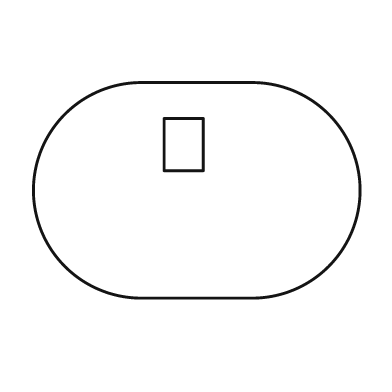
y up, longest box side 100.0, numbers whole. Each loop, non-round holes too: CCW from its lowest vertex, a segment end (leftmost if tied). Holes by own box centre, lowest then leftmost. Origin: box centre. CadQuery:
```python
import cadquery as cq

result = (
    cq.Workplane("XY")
    .moveTo(-17.0, -33.0)
    .lineTo(17.0, -33.0)
    .threePointArc((50.0, 0.0), (17.0, 33.0))
    .lineTo(-17.0, 33.0)
    .threePointArc((-50.0, 0.0), (-17.0, -33.0))
    .close()
    .moveTo(-10.0, 6.0)
    .lineTo(2.0, 6.0)
    .lineTo(2.0, 22.0)
    .lineTo(-10.0, 22.0)
    .close()
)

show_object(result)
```